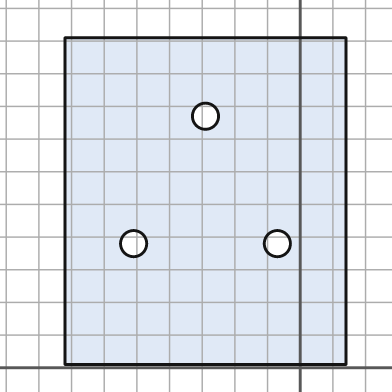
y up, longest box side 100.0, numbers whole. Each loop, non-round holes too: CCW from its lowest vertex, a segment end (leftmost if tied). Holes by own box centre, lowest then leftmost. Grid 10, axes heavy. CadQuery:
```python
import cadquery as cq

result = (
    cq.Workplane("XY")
    .moveTo(-72.0, 1.0)
    .lineTo(14.0, 1.0)
    .lineTo(14.0, 101.0)
    .lineTo(-72.0, 101.0)
    .close()
    .moveTo(-51.0, 38.0)
    .circle(4.0)
    .moveTo(-7.0, 38.0)
    .circle(4.0)
    .moveTo(-29.0, 77.0)
    .circle(4.0)
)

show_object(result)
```